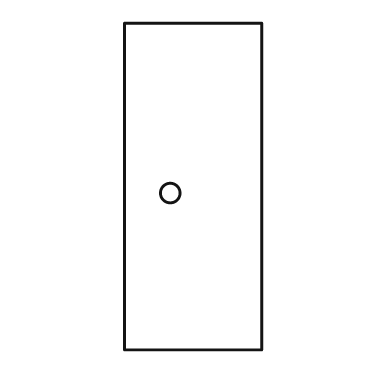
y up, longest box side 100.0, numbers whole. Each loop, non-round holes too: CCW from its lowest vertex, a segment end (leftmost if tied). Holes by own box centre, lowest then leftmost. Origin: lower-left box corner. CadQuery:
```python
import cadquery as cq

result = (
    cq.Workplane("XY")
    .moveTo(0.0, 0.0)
    .lineTo(42.0, 0.0)
    .lineTo(42.0, 100.0)
    .lineTo(0.0, 100.0)
    .close()
    .moveTo(14.0, 48.0)
    .circle(3.0)
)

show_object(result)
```